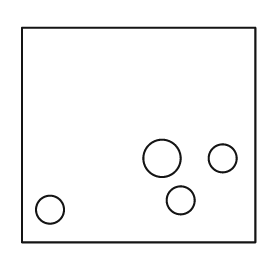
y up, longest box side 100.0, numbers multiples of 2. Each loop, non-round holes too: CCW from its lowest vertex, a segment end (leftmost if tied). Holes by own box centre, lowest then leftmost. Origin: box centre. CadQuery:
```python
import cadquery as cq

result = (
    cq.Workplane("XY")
    .moveTo(-50.0, -46.0)
    .lineTo(50.0, -46.0)
    .lineTo(50.0, 46.0)
    .lineTo(-50.0, 46.0)
    .close()
    .moveTo(-38.0, -32.0)
    .circle(6.0)
    .moveTo(18.0, -28.0)
    .circle(6.0)
    .moveTo(10.0, -10.0)
    .circle(8.0)
    .moveTo(36.0, -10.0)
    .circle(6.0)
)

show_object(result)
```